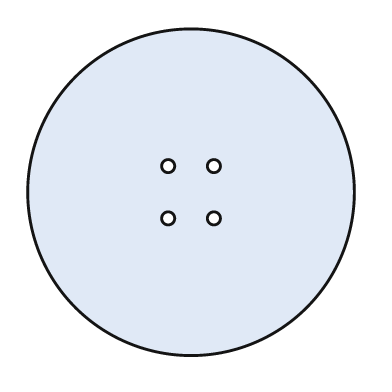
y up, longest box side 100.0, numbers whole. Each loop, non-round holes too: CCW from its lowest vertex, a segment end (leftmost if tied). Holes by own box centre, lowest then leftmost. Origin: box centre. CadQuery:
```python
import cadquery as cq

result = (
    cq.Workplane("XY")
    .moveTo(0.0, 0.0)
    .circle(50.0)
    .moveTo(-7.0, -8.0)
    .circle(2.0)
    .moveTo(7.0, -8.0)
    .circle(2.0)
    .moveTo(-7.0, 8.0)
    .circle(2.0)
    .moveTo(7.0, 8.0)
    .circle(2.0)
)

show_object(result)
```